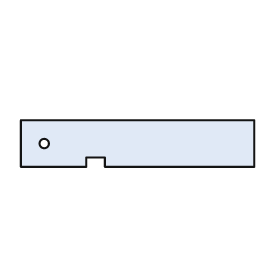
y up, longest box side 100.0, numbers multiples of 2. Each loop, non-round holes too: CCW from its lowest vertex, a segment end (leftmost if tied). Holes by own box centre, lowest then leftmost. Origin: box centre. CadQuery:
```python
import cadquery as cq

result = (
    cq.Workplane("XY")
    .moveTo(-50.0, -10.0)
    .lineTo(-22.0, -10.0)
    .lineTo(-22.0, -6.0)
    .lineTo(-14.0, -6.0)
    .lineTo(-14.0, -10.0)
    .lineTo(50.0, -10.0)
    .lineTo(50.0, 10.0)
    .lineTo(-50.0, 10.0)
    .close()
    .moveTo(-40.0, 0.0)
    .circle(2.0)
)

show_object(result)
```